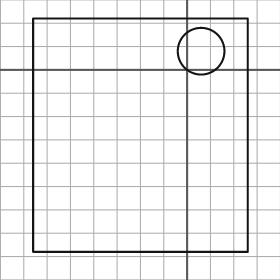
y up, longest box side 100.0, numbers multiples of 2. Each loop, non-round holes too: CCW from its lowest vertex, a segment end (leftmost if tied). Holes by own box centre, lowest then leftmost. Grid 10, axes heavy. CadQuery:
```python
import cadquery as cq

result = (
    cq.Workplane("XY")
    .moveTo(-66.0, -78.0)
    .lineTo(26.0, -78.0)
    .lineTo(26.0, 22.0)
    .lineTo(-66.0, 22.0)
    .close()
    .moveTo(6.0, 8.0)
    .circle(10.0)
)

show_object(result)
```